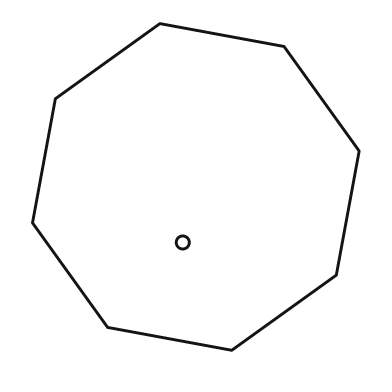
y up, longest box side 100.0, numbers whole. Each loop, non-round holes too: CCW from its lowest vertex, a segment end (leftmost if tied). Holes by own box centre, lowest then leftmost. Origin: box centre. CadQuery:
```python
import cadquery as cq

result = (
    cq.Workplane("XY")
    .moveTo(11.0, -50.0)
    .lineTo(43.0, -27.0)
    .lineTo(50.0, 11.0)
    .lineTo(27.0, 43.0)
    .lineTo(-11.0, 50.0)
    .lineTo(-43.0, 27.0)
    .lineTo(-50.0, -11.0)
    .lineTo(-27.0, -43.0)
    .close()
    .moveTo(-4.0, -17.0)
    .circle(2.0)
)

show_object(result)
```